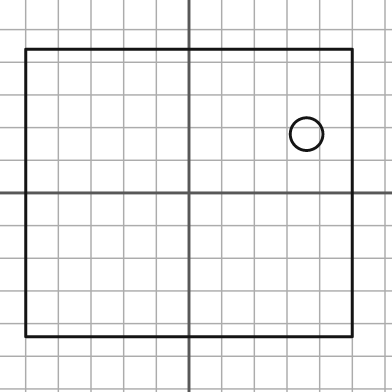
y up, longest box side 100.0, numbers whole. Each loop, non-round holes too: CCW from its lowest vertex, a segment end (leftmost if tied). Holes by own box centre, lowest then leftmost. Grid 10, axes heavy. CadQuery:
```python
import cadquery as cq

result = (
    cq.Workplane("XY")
    .moveTo(-50.0, -44.0)
    .lineTo(50.0, -44.0)
    .lineTo(50.0, 44.0)
    .lineTo(-50.0, 44.0)
    .close()
    .moveTo(36.0, 18.0)
    .circle(5.0)
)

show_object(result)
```